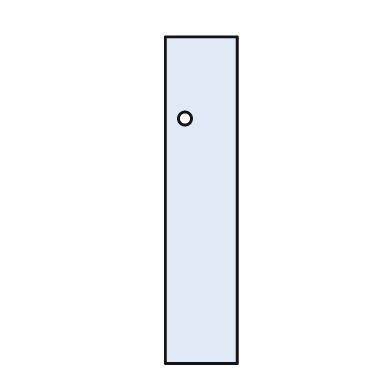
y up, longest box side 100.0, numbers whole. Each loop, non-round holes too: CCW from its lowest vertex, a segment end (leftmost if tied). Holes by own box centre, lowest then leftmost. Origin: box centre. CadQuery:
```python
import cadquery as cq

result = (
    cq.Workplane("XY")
    .moveTo(-11.0, -50.0)
    .lineTo(11.0, -50.0)
    .lineTo(11.0, 50.0)
    .lineTo(-11.0, 50.0)
    .close()
    .moveTo(-5.0, 25.0)
    .circle(2.0)
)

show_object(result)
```